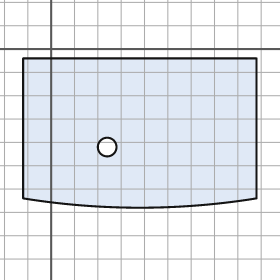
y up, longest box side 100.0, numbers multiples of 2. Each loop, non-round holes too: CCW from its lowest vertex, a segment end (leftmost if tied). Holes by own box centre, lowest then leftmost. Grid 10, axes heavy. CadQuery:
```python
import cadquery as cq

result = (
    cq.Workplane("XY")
    .moveTo(-12.0, -64.0)
    .threePointArc((38.0, -68.0), (88.0, -64.0))
    .lineTo(88.0, -4.0)
    .lineTo(-12.0, -4.0)
    .close()
    .moveTo(24.0, -42.0)
    .circle(4.0)
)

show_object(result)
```